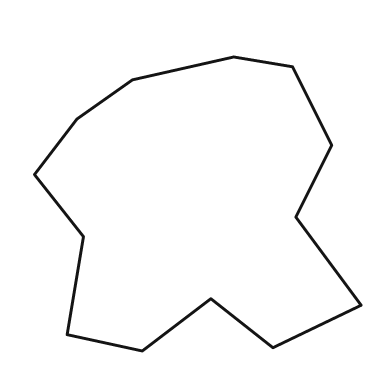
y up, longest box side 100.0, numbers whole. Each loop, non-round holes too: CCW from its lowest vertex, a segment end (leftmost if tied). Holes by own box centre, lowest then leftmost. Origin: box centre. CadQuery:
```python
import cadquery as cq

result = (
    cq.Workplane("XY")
    .moveTo(-17.0, -45.0)
    .lineTo(4.0, -29.0)
    .lineTo(23.0, -44.0)
    .lineTo(50.0, -31.0)
    .lineTo(30.0, -4.0)
    .lineTo(41.0, 18.0)
    .lineTo(29.0, 42.0)
    .lineTo(11.0, 45.0)
    .lineTo(-20.0, 38.0)
    .lineTo(-37.0, 26.0)
    .lineTo(-50.0, 9.0)
    .lineTo(-35.0, -10.0)
    .lineTo(-40.0, -40.0)
    .close()
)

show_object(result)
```